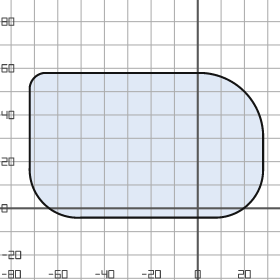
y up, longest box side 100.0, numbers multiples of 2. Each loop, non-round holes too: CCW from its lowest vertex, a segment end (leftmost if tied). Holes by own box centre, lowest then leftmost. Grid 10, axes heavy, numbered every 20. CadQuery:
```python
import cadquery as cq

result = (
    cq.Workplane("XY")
    .moveTo(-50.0, -4.0)
    .lineTo(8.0, -4.0)
    .threePointArc((22.0, 2.0), (28.0, 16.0))
    .lineTo(28.0, 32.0)
    .threePointArc((20.0, 50.0), (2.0, 58.0))
    .lineTo(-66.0, 58.0)
    .threePointArc((-70.0, 56.0), (-72.0, 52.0))
    .lineTo(-72.0, 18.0)
    .threePointArc((-66.0, 2.0), (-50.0, -4.0))
    .close()
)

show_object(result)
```